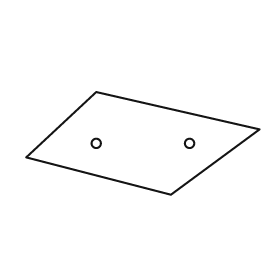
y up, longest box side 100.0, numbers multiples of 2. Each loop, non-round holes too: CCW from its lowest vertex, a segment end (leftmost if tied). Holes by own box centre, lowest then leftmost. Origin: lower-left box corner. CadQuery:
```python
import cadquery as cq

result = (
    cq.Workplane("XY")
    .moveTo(62.0, 0.0)
    .lineTo(100.0, 28.0)
    .lineTo(30.0, 44.0)
    .lineTo(0.0, 16.0)
    .close()
    .moveTo(30.0, 22.0)
    .circle(2.0)
    .moveTo(70.0, 22.0)
    .circle(2.0)
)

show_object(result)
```